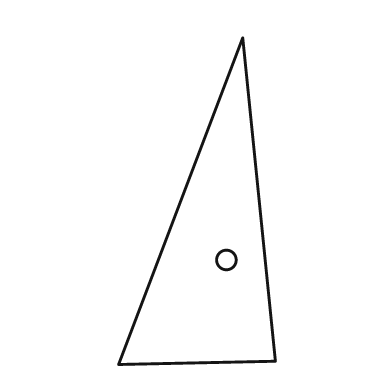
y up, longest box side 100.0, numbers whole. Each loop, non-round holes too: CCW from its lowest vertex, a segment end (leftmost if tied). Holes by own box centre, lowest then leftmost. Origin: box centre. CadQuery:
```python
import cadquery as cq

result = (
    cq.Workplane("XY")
    .moveTo(-24.0, -50.0)
    .lineTo(24.0, -49.0)
    .lineTo(14.0, 50.0)
    .close()
    .moveTo(9.0, -18.0)
    .circle(3.0)
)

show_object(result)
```